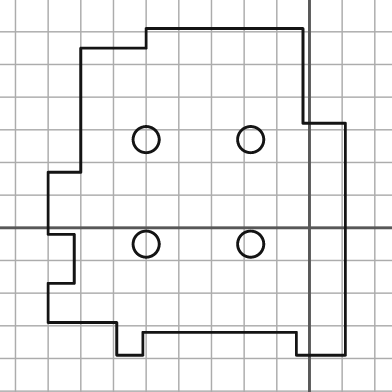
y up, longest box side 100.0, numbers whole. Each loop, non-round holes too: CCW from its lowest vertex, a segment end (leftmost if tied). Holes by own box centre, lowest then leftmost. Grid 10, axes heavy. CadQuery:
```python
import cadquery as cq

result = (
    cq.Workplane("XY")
    .moveTo(-59.0, -39.0)
    .lineTo(-51.0, -39.0)
    .lineTo(-51.0, -32.0)
    .lineTo(-4.0, -32.0)
    .lineTo(-4.0, -39.0)
    .lineTo(11.0, -39.0)
    .lineTo(11.0, 32.0)
    .lineTo(-2.0, 32.0)
    .lineTo(-2.0, 61.0)
    .lineTo(-50.0, 61.0)
    .lineTo(-50.0, 55.0)
    .lineTo(-70.0, 55.0)
    .lineTo(-70.0, 17.0)
    .lineTo(-80.0, 17.0)
    .lineTo(-80.0, -2.0)
    .lineTo(-72.0, -2.0)
    .lineTo(-72.0, -17.0)
    .lineTo(-80.0, -17.0)
    .lineTo(-80.0, -29.0)
    .lineTo(-59.0, -29.0)
    .close()
    .moveTo(-50.0, -5.0)
    .circle(4.0)
    .moveTo(-18.0, -5.0)
    .circle(4.0)
    .moveTo(-50.0, 27.0)
    .circle(4.0)
    .moveTo(-18.0, 27.0)
    .circle(4.0)
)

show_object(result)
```